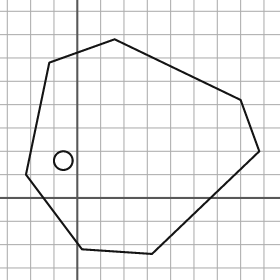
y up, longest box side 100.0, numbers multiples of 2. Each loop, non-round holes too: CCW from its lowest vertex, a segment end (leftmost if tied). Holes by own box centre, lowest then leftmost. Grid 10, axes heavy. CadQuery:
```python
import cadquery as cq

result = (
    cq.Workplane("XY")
    .moveTo(32.0, -24.0)
    .lineTo(78.0, 20.0)
    .lineTo(70.0, 42.0)
    .lineTo(16.0, 68.0)
    .lineTo(-12.0, 58.0)
    .lineTo(-22.0, 10.0)
    .lineTo(2.0, -22.0)
    .close()
    .moveTo(-6.0, 16.0)
    .circle(4.0)
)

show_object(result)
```